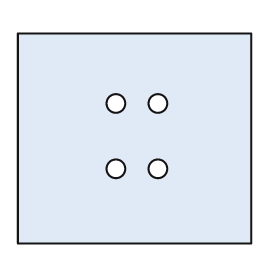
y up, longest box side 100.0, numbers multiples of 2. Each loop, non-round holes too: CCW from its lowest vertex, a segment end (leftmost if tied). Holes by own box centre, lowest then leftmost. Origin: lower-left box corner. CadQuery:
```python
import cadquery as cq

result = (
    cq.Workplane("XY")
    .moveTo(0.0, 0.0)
    .lineTo(100.0, 0.0)
    .lineTo(100.0, 90.0)
    .lineTo(0.0, 90.0)
    .close()
    .moveTo(42.0, 32.0)
    .circle(4.0)
    .moveTo(60.0, 32.0)
    .circle(4.0)
    .moveTo(42.0, 60.0)
    .circle(4.0)
    .moveTo(60.0, 60.0)
    .circle(4.0)
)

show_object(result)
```